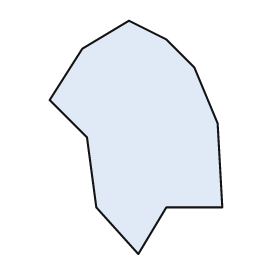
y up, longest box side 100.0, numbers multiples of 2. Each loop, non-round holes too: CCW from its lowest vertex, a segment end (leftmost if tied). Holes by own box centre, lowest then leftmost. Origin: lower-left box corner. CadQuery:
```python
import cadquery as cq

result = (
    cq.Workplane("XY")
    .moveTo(38.0, 0.0)
    .lineTo(50.0, 20.0)
    .lineTo(74.0, 20.0)
    .lineTo(72.0, 56.0)
    .lineTo(62.0, 80.0)
    .lineTo(50.0, 92.0)
    .lineTo(34.0, 100.0)
    .lineTo(14.0, 88.0)
    .lineTo(0.0, 66.0)
    .lineTo(16.0, 50.0)
    .lineTo(20.0, 20.0)
    .close()
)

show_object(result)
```